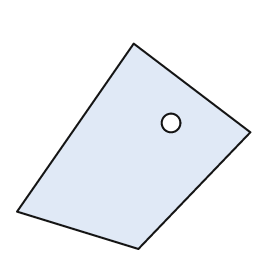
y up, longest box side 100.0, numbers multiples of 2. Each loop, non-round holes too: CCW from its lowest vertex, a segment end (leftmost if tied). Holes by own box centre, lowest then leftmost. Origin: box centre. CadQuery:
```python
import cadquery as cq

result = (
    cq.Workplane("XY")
    .moveTo(2.0, -44.0)
    .lineTo(50.0, 6.0)
    .lineTo(0.0, 44.0)
    .lineTo(-50.0, -28.0)
    .close()
    .moveTo(16.0, 10.0)
    .circle(4.0)
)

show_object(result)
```